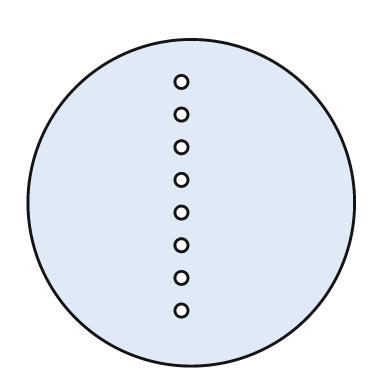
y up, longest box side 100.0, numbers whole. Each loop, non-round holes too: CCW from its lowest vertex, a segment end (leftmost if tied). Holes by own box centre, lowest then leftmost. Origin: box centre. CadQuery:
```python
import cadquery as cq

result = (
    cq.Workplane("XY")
    .moveTo(0.0, 0.0)
    .circle(50.0)
    .moveTo(-3.0, -33.0)
    .circle(2.0)
    .moveTo(-3.0, -23.0)
    .circle(2.0)
    .moveTo(-3.0, -13.0)
    .circle(2.0)
    .moveTo(-3.0, -3.0)
    .circle(2.0)
    .moveTo(-3.0, 7.0)
    .circle(2.0)
    .moveTo(-3.0, 17.0)
    .circle(2.0)
    .moveTo(-3.0, 27.0)
    .circle(2.0)
    .moveTo(-3.0, 37.0)
    .circle(2.0)
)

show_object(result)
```